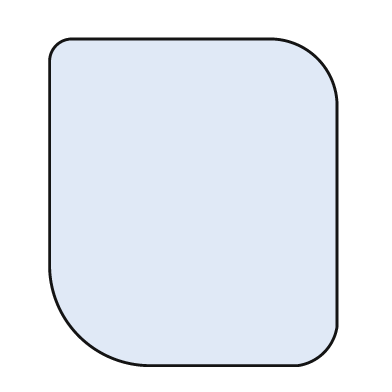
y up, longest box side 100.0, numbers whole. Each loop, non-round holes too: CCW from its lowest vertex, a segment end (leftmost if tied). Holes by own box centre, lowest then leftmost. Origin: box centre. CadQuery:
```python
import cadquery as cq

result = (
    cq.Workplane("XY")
    .moveTo(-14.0, -50.0)
    .lineTo(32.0, -50.0)
    .threePointArc((40.0, -46.0), (44.0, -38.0))
    .lineTo(44.0, 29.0)
    .threePointArc((38.0, 44.0), (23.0, 50.0))
    .lineTo(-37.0, 50.0)
    .threePointArc((-42.0, 48.0), (-44.0, 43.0))
    .lineTo(-44.0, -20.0)
    .threePointArc((-35.0, -41.0), (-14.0, -50.0))
    .close()
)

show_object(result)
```